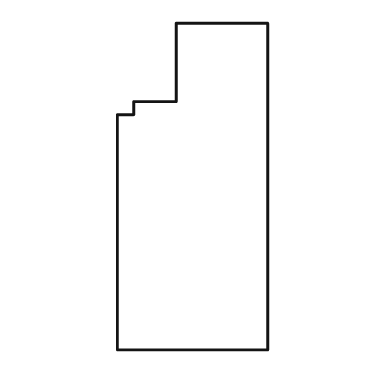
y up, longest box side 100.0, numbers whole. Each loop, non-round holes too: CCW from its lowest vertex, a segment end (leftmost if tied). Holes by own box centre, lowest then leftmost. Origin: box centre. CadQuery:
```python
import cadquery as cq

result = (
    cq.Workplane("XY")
    .moveTo(-23.0, -50.0)
    .lineTo(23.0, -50.0)
    .lineTo(23.0, 50.0)
    .lineTo(-5.0, 50.0)
    .lineTo(-5.0, 26.0)
    .lineTo(-18.0, 26.0)
    .lineTo(-18.0, 22.0)
    .lineTo(-23.0, 22.0)
    .close()
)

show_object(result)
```